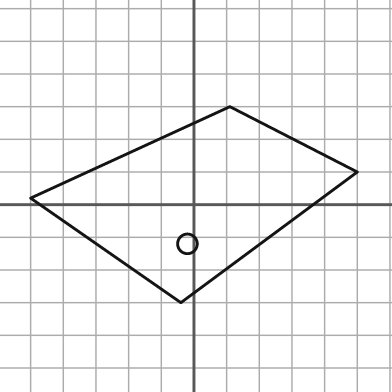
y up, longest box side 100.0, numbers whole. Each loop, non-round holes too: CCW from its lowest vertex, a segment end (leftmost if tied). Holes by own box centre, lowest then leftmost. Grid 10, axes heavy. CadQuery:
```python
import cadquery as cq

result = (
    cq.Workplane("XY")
    .moveTo(-4.0, -30.0)
    .lineTo(50.0, 10.0)
    .lineTo(11.0, 30.0)
    .lineTo(-50.0, 2.0)
    .close()
    .moveTo(-2.0, -12.0)
    .circle(3.0)
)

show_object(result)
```